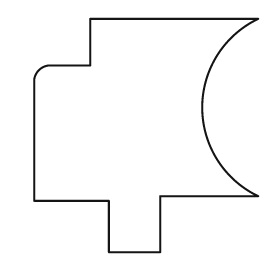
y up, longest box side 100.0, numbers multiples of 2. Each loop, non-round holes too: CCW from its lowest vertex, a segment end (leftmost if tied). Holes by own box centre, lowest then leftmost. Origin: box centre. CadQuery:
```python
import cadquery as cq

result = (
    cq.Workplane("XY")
    .moveTo(-16.0, -50.0)
    .lineTo(6.0, -50.0)
    .lineTo(6.0, -26.0)
    .lineTo(48.0, -26.0)
    .threePointArc((24.0, 12.0), (48.0, 50.0))
    .lineTo(-24.0, 50.0)
    .lineTo(-24.0, 30.0)
    .lineTo(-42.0, 30.0)
    .threePointArc((-46.0, 28.0), (-48.0, 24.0))
    .lineTo(-48.0, -28.0)
    .lineTo(-16.0, -28.0)
    .close()
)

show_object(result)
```